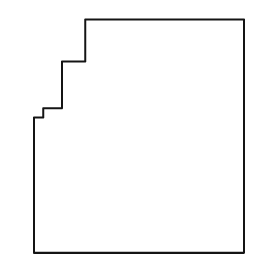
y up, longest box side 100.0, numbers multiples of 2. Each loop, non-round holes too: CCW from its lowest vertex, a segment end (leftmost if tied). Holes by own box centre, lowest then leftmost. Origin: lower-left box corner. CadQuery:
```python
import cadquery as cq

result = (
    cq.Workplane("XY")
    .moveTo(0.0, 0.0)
    .lineTo(90.0, 0.0)
    .lineTo(90.0, 100.0)
    .lineTo(22.0, 100.0)
    .lineTo(22.0, 82.0)
    .lineTo(12.0, 82.0)
    .lineTo(12.0, 62.0)
    .lineTo(4.0, 62.0)
    .lineTo(4.0, 58.0)
    .lineTo(0.0, 58.0)
    .close()
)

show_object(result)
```